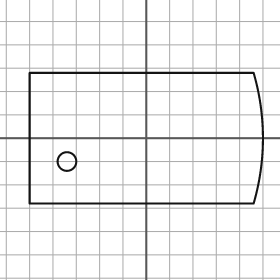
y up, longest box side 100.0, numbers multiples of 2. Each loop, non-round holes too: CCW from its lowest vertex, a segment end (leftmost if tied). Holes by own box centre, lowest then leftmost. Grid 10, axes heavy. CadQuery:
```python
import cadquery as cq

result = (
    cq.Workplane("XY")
    .moveTo(-50.0, -28.0)
    .lineTo(46.0, -28.0)
    .threePointArc((50.0, 0.0), (46.0, 28.0))
    .lineTo(-50.0, 28.0)
    .close()
    .moveTo(-34.0, -10.0)
    .circle(4.0)
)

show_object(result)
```